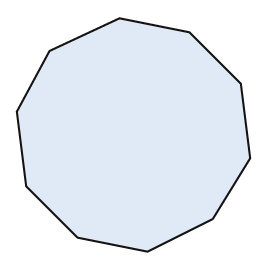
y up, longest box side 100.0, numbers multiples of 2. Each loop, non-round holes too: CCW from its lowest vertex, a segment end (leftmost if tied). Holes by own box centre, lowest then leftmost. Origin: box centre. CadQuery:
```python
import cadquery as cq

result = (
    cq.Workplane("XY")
    .moveTo(6.0, -50.0)
    .lineTo(34.0, -36.0)
    .lineTo(50.0, -10.0)
    .lineTo(46.0, 22.0)
    .lineTo(24.0, 44.0)
    .lineTo(-6.0, 50.0)
    .lineTo(-36.0, 36.0)
    .lineTo(-50.0, 10.0)
    .lineTo(-46.0, -22.0)
    .lineTo(-24.0, -44.0)
    .close()
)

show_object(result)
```